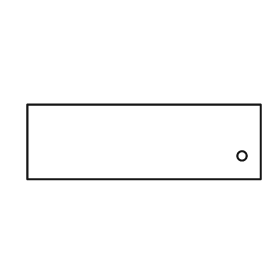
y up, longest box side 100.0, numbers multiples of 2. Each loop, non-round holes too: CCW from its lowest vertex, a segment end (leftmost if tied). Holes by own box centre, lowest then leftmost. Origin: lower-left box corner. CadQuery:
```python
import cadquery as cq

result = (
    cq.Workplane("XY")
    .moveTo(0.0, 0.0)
    .lineTo(100.0, 0.0)
    .lineTo(100.0, 32.0)
    .lineTo(0.0, 32.0)
    .close()
    .moveTo(92.0, 10.0)
    .circle(2.0)
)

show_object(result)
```